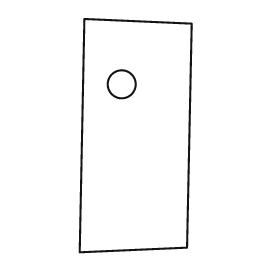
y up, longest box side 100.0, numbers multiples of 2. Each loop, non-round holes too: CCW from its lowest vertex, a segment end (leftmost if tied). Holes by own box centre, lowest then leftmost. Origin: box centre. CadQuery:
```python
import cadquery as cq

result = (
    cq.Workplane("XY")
    .moveTo(-24.0, -50.0)
    .lineTo(22.0, -48.0)
    .lineTo(24.0, 48.0)
    .lineTo(-22.0, 50.0)
    .close()
    .moveTo(-6.0, 22.0)
    .circle(6.0)
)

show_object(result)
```